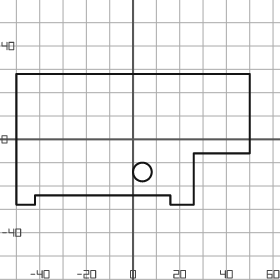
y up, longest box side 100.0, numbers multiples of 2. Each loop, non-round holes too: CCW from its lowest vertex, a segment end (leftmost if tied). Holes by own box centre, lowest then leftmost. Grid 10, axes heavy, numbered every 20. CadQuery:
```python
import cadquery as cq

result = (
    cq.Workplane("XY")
    .moveTo(-50.0, -28.0)
    .lineTo(-42.0, -28.0)
    .lineTo(-42.0, -24.0)
    .lineTo(16.0, -24.0)
    .lineTo(16.0, -28.0)
    .lineTo(26.0, -28.0)
    .lineTo(26.0, -6.0)
    .lineTo(50.0, -6.0)
    .lineTo(50.0, 28.0)
    .lineTo(-50.0, 28.0)
    .close()
    .moveTo(4.0, -14.0)
    .circle(4.0)
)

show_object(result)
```